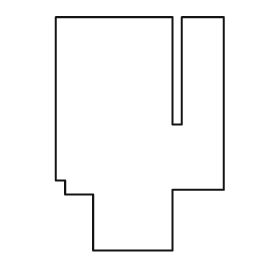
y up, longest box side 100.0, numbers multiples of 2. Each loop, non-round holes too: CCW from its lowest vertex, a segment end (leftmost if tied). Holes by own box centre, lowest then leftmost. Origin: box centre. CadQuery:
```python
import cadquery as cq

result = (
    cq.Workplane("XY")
    .moveTo(-20.0, -50.0)
    .lineTo(14.0, -50.0)
    .lineTo(14.0, -24.0)
    .lineTo(36.0, -24.0)
    .lineTo(36.0, 50.0)
    .lineTo(18.0, 50.0)
    .lineTo(18.0, 4.0)
    .lineTo(14.0, 4.0)
    .lineTo(14.0, 50.0)
    .lineTo(-36.0, 50.0)
    .lineTo(-36.0, -20.0)
    .lineTo(-32.0, -20.0)
    .lineTo(-32.0, -26.0)
    .lineTo(-20.0, -26.0)
    .close()
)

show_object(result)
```